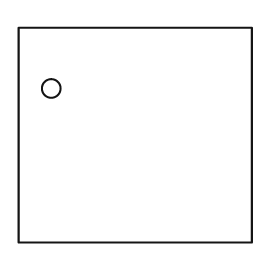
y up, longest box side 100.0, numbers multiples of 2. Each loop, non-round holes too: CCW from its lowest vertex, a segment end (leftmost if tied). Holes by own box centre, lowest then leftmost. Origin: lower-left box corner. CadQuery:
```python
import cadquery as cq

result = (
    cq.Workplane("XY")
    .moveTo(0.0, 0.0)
    .lineTo(100.0, 0.0)
    .lineTo(100.0, 92.0)
    .lineTo(0.0, 92.0)
    .close()
    .moveTo(14.0, 66.0)
    .circle(4.0)
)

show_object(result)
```